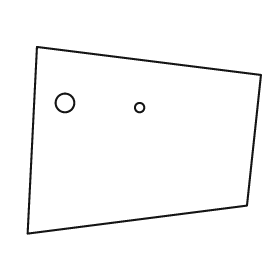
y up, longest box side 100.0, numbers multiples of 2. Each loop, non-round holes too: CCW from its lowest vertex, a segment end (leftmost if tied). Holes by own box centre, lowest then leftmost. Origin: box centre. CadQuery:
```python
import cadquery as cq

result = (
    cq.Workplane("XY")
    .moveTo(-50.0, -40.0)
    .lineTo(44.0, -28.0)
    .lineTo(50.0, 28.0)
    .lineTo(-46.0, 40.0)
    .close()
    .moveTo(-2.0, 14.0)
    .circle(2.0)
    .moveTo(-34.0, 16.0)
    .circle(4.0)
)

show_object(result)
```